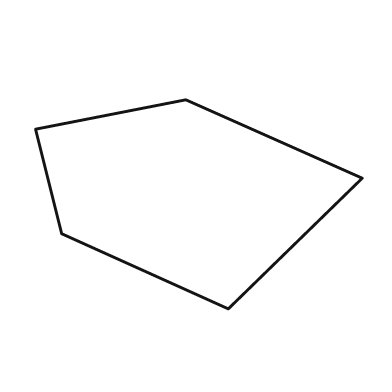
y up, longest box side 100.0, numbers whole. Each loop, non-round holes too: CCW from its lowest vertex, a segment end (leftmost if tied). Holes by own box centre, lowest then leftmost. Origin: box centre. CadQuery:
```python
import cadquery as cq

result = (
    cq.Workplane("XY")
    .moveTo(9.0, -32.0)
    .lineTo(50.0, 8.0)
    .lineTo(-4.0, 32.0)
    .lineTo(-50.0, 23.0)
    .lineTo(-42.0, -9.0)
    .close()
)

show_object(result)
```